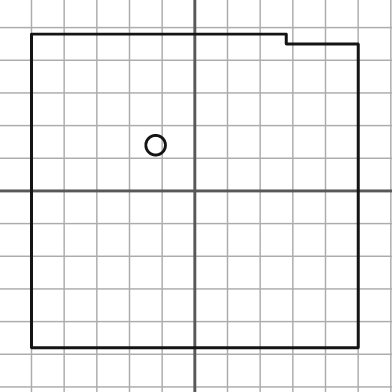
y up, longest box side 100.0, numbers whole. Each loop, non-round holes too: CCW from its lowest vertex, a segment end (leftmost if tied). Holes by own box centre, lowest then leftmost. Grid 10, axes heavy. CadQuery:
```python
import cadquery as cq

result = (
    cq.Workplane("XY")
    .moveTo(-50.0, -48.0)
    .lineTo(50.0, -48.0)
    .lineTo(50.0, 45.0)
    .lineTo(28.0, 45.0)
    .lineTo(28.0, 48.0)
    .lineTo(-50.0, 48.0)
    .close()
    .moveTo(-12.0, 14.0)
    .circle(3.0)
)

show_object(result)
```